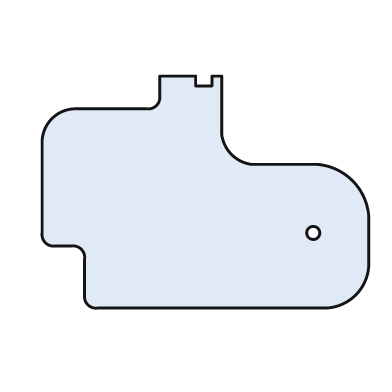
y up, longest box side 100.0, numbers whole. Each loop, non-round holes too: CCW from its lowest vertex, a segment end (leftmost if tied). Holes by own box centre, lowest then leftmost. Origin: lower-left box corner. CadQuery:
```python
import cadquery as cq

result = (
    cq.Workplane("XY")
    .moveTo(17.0, 0.0)
    .lineTo(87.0, 0.0)
    .threePointArc((96.0, 4.0), (100.0, 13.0))
    .lineTo(100.0, 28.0)
    .threePointArc((95.0, 39.0), (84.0, 44.0))
    .lineTo(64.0, 44.0)
    .threePointArc((58.0, 47.0), (55.0, 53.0))
    .lineTo(55.0, 71.0)
    .lineTo(52.0, 71.0)
    .lineTo(52.0, 68.0)
    .lineTo(47.0, 68.0)
    .lineTo(47.0, 71.0)
    .lineTo(36.0, 71.0)
    .lineTo(36.0, 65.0)
    .threePointArc((35.0, 62.0), (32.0, 61.0))
    .lineTo(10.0, 61.0)
    .threePointArc((3.0, 58.0), (0.0, 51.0))
    .lineTo(0.0, 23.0)
    .threePointArc((1.0, 20.0), (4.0, 19.0))
    .lineTo(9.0, 19.0)
    .threePointArc((12.0, 18.0), (13.0, 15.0))
    .lineTo(13.0, 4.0)
    .threePointArc((14.0, 1.0), (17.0, 0.0))
    .close()
    .moveTo(83.0, 23.0)
    .circle(2.0)
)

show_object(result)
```